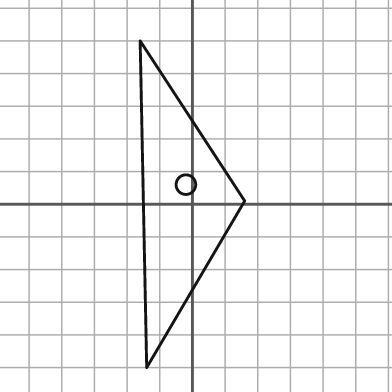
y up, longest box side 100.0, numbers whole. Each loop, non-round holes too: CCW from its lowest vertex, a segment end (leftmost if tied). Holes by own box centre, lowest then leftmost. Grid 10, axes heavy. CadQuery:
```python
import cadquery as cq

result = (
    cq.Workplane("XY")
    .moveTo(-14.0, -50.0)
    .lineTo(16.0, 1.0)
    .lineTo(-16.0, 50.0)
    .close()
    .moveTo(-2.0, 6.0)
    .circle(3.0)
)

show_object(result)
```